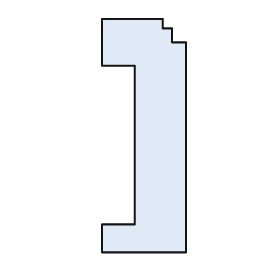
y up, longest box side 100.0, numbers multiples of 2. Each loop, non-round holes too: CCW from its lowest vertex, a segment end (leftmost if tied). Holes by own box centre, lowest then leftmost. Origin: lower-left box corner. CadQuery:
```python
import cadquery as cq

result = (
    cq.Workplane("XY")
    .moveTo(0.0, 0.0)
    .lineTo(36.0, 0.0)
    .lineTo(36.0, 90.0)
    .lineTo(30.0, 90.0)
    .lineTo(30.0, 96.0)
    .lineTo(26.0, 96.0)
    .lineTo(26.0, 100.0)
    .lineTo(0.0, 100.0)
    .lineTo(0.0, 80.0)
    .lineTo(14.0, 80.0)
    .lineTo(14.0, 12.0)
    .lineTo(0.0, 12.0)
    .close()
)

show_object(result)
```